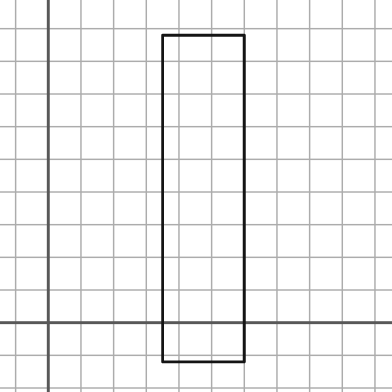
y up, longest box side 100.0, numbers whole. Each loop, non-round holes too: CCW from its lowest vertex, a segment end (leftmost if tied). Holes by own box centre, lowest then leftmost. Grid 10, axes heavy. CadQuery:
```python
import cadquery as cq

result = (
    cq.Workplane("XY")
    .moveTo(35.0, -12.0)
    .lineTo(60.0, -12.0)
    .lineTo(60.0, 88.0)
    .lineTo(35.0, 88.0)
    .close()
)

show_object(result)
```